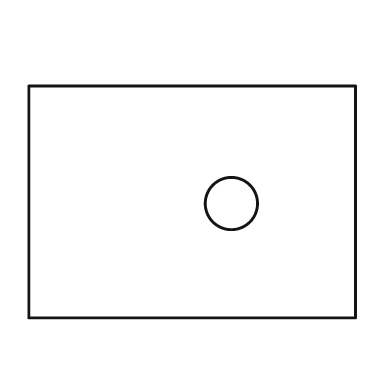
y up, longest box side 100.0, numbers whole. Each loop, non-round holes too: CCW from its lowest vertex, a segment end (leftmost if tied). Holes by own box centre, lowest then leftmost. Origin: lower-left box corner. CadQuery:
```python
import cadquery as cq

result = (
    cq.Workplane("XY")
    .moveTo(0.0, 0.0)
    .lineTo(100.0, 0.0)
    .lineTo(100.0, 71.0)
    .lineTo(0.0, 71.0)
    .close()
    .moveTo(62.0, 35.0)
    .circle(8.0)
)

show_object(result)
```